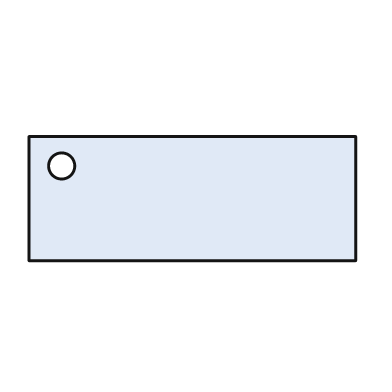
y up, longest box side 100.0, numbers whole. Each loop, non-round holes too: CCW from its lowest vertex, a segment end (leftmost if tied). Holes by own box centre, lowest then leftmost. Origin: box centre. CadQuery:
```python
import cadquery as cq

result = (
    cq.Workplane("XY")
    .moveTo(-50.0, -19.0)
    .lineTo(50.0, -19.0)
    .lineTo(50.0, 19.0)
    .lineTo(-50.0, 19.0)
    .close()
    .moveTo(-40.0, 10.0)
    .circle(4.0)
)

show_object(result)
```